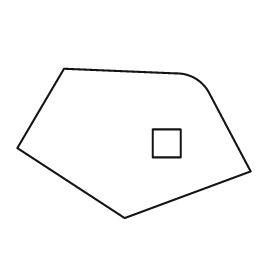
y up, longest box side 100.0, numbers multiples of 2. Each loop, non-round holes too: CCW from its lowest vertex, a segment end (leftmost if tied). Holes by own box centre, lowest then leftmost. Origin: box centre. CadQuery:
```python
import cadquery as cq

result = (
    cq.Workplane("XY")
    .moveTo(-4.0, -32.0)
    .lineTo(50.0, -12.0)
    .lineTo(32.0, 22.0)
    .threePointArc((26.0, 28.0), (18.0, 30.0))
    .lineTo(-30.0, 32.0)
    .lineTo(-50.0, -2.0)
    .close()
    .moveTo(8.0, -6.0)
    .lineTo(20.0, -6.0)
    .lineTo(20.0, 6.0)
    .lineTo(8.0, 6.0)
    .close()
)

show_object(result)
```